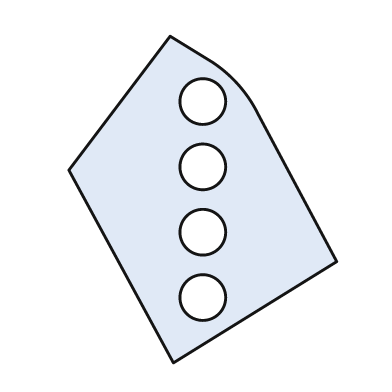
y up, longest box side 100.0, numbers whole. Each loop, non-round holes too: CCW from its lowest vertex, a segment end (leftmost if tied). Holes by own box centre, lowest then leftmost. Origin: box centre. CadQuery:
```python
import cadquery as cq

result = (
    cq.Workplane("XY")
    .moveTo(-9.0, -50.0)
    .lineTo(41.0, -19.0)
    .lineTo(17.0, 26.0)
    .threePointArc((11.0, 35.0), (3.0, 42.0))
    .lineTo(-10.0, 50.0)
    .lineTo(-41.0, 9.0)
    .close()
    .moveTo(0.0, -30.0)
    .circle(7.0)
    .moveTo(0.0, -10.0)
    .circle(7.0)
    .moveTo(0.0, 10.0)
    .circle(7.0)
    .moveTo(0.0, 30.0)
    .circle(7.0)
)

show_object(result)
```